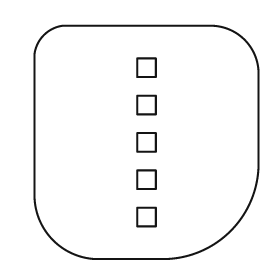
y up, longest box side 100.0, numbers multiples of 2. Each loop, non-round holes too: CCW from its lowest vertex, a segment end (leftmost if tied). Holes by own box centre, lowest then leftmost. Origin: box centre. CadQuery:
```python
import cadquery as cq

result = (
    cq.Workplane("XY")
    .moveTo(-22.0, -50.0)
    .lineTo(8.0, -50.0)
    .threePointArc((36.0, -38.0), (48.0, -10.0))
    .lineTo(48.0, 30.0)
    .threePointArc((42.0, 44.0), (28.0, 50.0))
    .lineTo(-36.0, 50.0)
    .threePointArc((-44.0, 46.0), (-48.0, 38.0))
    .lineTo(-48.0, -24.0)
    .threePointArc((-40.0, -42.0), (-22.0, -50.0))
    .close()
    .moveTo(-4.0, -36.0)
    .lineTo(4.0, -36.0)
    .lineTo(4.0, -28.0)
    .lineTo(-4.0, -28.0)
    .close()
    .moveTo(-4.0, -20.0)
    .lineTo(4.0, -20.0)
    .lineTo(4.0, -12.0)
    .lineTo(-4.0, -12.0)
    .close()
    .moveTo(-4.0, -4.0)
    .lineTo(4.0, -4.0)
    .lineTo(4.0, 4.0)
    .lineTo(-4.0, 4.0)
    .close()
    .moveTo(-4.0, 12.0)
    .lineTo(4.0, 12.0)
    .lineTo(4.0, 20.0)
    .lineTo(-4.0, 20.0)
    .close()
    .moveTo(-4.0, 28.0)
    .lineTo(4.0, 28.0)
    .lineTo(4.0, 36.0)
    .lineTo(-4.0, 36.0)
    .close()
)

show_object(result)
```